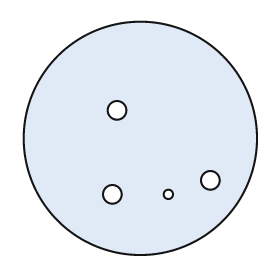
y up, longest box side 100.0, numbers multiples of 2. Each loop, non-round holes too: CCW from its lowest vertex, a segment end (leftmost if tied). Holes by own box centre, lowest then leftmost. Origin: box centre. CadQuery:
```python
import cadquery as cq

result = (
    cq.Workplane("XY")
    .moveTo(0.0, 0.0)
    .circle(50.0)
    .moveTo(-12.0, -24.0)
    .circle(4.0)
    .moveTo(12.0, -24.0)
    .circle(2.0)
    .moveTo(30.0, -18.0)
    .circle(4.0)
    .moveTo(-10.0, 12.0)
    .circle(4.0)
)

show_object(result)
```